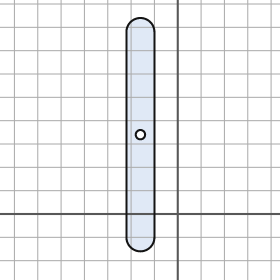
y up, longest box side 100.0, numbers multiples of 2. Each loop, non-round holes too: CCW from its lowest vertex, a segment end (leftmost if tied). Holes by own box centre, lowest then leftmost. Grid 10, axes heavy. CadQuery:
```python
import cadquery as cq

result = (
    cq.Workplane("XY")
    .moveTo(-22.0, -10.0)
    .threePointArc((-16.0, -16.0), (-10.0, -10.0))
    .lineTo(-10.0, 78.0)
    .threePointArc((-16.0, 84.0), (-22.0, 78.0))
    .close()
    .moveTo(-16.0, 34.0)
    .circle(2.0)
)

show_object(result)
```